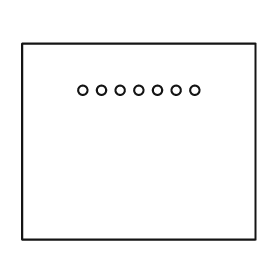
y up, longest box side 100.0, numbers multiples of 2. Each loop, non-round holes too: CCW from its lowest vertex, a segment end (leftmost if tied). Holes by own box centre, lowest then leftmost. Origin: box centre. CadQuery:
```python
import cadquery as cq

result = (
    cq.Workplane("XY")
    .moveTo(-50.0, -42.0)
    .lineTo(50.0, -42.0)
    .lineTo(50.0, 42.0)
    .lineTo(-50.0, 42.0)
    .close()
    .moveTo(-24.0, 22.0)
    .circle(2.0)
    .moveTo(-16.0, 22.0)
    .circle(2.0)
    .moveTo(-8.0, 22.0)
    .circle(2.0)
    .moveTo(0.0, 22.0)
    .circle(2.0)
    .moveTo(8.0, 22.0)
    .circle(2.0)
    .moveTo(16.0, 22.0)
    .circle(2.0)
    .moveTo(24.0, 22.0)
    .circle(2.0)
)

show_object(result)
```